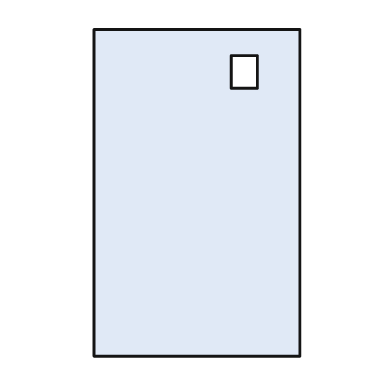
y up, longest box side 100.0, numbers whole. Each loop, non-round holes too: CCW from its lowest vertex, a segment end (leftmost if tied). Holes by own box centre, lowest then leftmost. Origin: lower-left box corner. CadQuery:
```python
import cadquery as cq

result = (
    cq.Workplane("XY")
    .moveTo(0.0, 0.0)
    .lineTo(63.0, 0.0)
    .lineTo(63.0, 100.0)
    .lineTo(0.0, 100.0)
    .close()
    .moveTo(42.0, 82.0)
    .lineTo(50.0, 82.0)
    .lineTo(50.0, 92.0)
    .lineTo(42.0, 92.0)
    .close()
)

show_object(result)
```